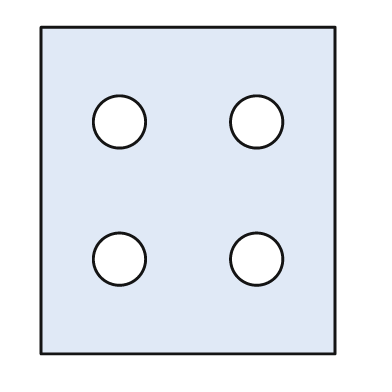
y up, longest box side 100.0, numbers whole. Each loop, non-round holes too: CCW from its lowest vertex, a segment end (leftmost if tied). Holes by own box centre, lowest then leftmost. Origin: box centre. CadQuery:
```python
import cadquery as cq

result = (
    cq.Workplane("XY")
    .moveTo(-45.0, -50.0)
    .lineTo(45.0, -50.0)
    .lineTo(45.0, 50.0)
    .lineTo(-45.0, 50.0)
    .close()
    .moveTo(-21.0, -21.0)
    .circle(8.0)
    .moveTo(21.0, -21.0)
    .circle(8.0)
    .moveTo(-21.0, 21.0)
    .circle(8.0)
    .moveTo(21.0, 21.0)
    .circle(8.0)
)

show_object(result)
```